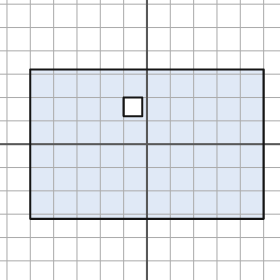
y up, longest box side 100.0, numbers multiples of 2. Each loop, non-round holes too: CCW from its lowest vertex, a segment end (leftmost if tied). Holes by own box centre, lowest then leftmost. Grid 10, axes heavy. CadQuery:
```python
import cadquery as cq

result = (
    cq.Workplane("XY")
    .moveTo(-50.0, -32.0)
    .lineTo(50.0, -32.0)
    .lineTo(50.0, 32.0)
    .lineTo(-50.0, 32.0)
    .close()
    .moveTo(-10.0, 12.0)
    .lineTo(-2.0, 12.0)
    .lineTo(-2.0, 20.0)
    .lineTo(-10.0, 20.0)
    .close()
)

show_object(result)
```